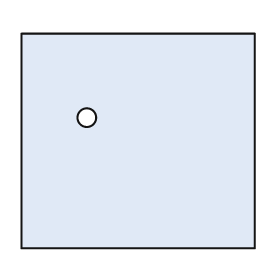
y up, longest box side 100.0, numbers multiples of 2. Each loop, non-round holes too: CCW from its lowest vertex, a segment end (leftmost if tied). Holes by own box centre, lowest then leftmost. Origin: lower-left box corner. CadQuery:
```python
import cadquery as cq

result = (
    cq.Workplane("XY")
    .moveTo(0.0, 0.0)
    .lineTo(100.0, 0.0)
    .lineTo(100.0, 92.0)
    .lineTo(0.0, 92.0)
    .close()
    .moveTo(28.0, 56.0)
    .circle(4.0)
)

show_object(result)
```